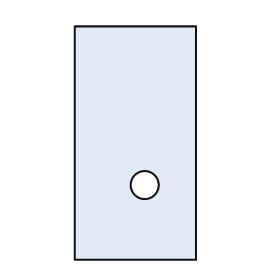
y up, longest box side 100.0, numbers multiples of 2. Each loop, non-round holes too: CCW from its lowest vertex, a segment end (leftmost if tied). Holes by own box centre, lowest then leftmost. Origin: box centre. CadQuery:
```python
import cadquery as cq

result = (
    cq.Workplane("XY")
    .moveTo(-26.0, -50.0)
    .lineTo(26.0, -50.0)
    .lineTo(26.0, 50.0)
    .lineTo(-26.0, 50.0)
    .close()
    .moveTo(4.0, -18.0)
    .circle(6.0)
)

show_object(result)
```